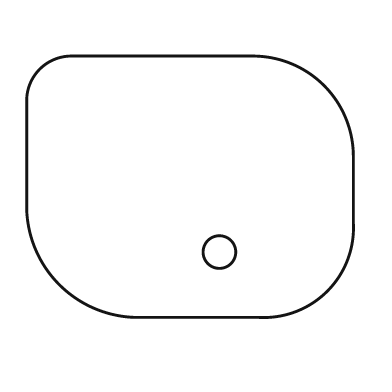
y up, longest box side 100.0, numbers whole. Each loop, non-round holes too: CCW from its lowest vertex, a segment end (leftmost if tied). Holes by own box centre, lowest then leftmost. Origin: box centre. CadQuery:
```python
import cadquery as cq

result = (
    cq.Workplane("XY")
    .moveTo(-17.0, -40.0)
    .lineTo(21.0, -40.0)
    .threePointArc((42.0, -32.0), (50.0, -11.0))
    .lineTo(50.0, 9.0)
    .threePointArc((41.0, 31.0), (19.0, 40.0))
    .lineTo(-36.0, 40.0)
    .threePointArc((-46.0, 36.0), (-50.0, 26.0))
    .lineTo(-50.0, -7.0)
    .threePointArc((-40.0, -30.0), (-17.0, -40.0))
    .close()
    .moveTo(9.0, -20.0)
    .circle(5.0)
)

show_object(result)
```